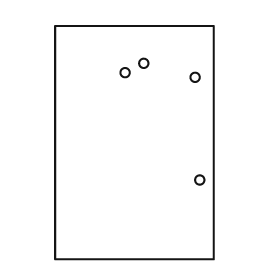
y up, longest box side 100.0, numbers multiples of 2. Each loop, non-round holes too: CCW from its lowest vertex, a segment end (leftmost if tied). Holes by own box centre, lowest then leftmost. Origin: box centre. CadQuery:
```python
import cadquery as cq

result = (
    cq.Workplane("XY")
    .moveTo(-34.0, -50.0)
    .lineTo(34.0, -50.0)
    .lineTo(34.0, 50.0)
    .lineTo(-34.0, 50.0)
    .close()
    .moveTo(28.0, -16.0)
    .circle(2.0)
    .moveTo(26.0, 28.0)
    .circle(2.0)
    .moveTo(-4.0, 30.0)
    .circle(2.0)
    .moveTo(4.0, 34.0)
    .circle(2.0)
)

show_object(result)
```